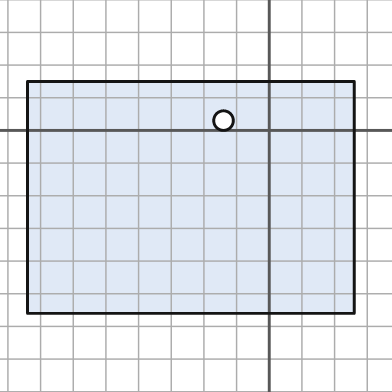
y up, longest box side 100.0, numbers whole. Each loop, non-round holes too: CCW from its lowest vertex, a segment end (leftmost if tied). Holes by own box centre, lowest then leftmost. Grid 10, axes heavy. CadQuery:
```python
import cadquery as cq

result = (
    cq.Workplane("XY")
    .moveTo(-74.0, -56.0)
    .lineTo(26.0, -56.0)
    .lineTo(26.0, 15.0)
    .lineTo(-74.0, 15.0)
    .close()
    .moveTo(-14.0, 3.0)
    .circle(3.0)
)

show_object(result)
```